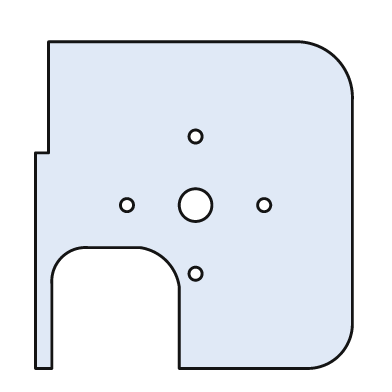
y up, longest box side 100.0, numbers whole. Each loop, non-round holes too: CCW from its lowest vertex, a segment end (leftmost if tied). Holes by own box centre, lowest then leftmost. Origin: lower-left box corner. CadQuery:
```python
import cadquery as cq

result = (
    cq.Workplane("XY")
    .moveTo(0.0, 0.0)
    .lineTo(5.0, 0.0)
    .lineTo(5.0, 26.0)
    .threePointArc((8.0, 34.0), (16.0, 37.0))
    .lineTo(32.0, 37.0)
    .threePointArc((40.0, 33.0), (44.0, 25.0))
    .lineTo(44.0, 0.0)
    .lineTo(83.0, 0.0)
    .threePointArc((93.0, 4.0), (97.0, 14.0))
    .lineTo(97.0, 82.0)
    .threePointArc((92.0, 95.0), (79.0, 100.0))
    .lineTo(4.0, 100.0)
    .lineTo(4.0, 66.0)
    .lineTo(0.0, 66.0)
    .close()
    .moveTo(49.0, 29.0)
    .circle(2.0)
    .moveTo(28.0, 50.0)
    .circle(2.0)
    .moveTo(49.0, 50.0)
    .circle(5.0)
    .moveTo(70.0, 50.0)
    .circle(2.0)
    .moveTo(49.0, 71.0)
    .circle(2.0)
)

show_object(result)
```